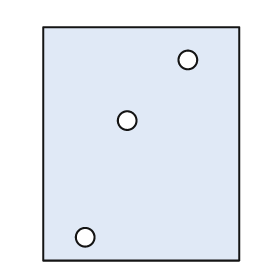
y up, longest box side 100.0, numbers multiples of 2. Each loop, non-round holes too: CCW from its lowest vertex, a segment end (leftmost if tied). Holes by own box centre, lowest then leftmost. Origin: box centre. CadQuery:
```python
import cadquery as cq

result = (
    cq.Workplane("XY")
    .moveTo(-42.0, -50.0)
    .lineTo(42.0, -50.0)
    .lineTo(42.0, 50.0)
    .lineTo(-42.0, 50.0)
    .close()
    .moveTo(-24.0, -40.0)
    .circle(4.0)
    .moveTo(-6.0, 10.0)
    .circle(4.0)
    .moveTo(20.0, 36.0)
    .circle(4.0)
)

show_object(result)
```